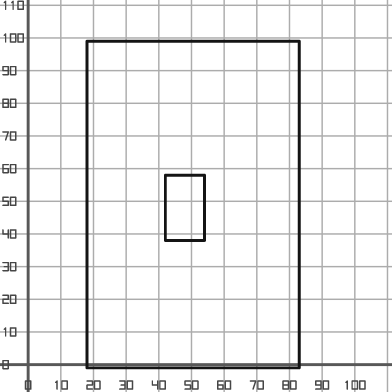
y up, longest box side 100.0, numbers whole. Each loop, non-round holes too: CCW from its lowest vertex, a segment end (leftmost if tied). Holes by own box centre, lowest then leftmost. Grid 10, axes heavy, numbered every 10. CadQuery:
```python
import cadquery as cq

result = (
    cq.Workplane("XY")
    .moveTo(18.0, -1.0)
    .lineTo(83.0, -1.0)
    .lineTo(83.0, 99.0)
    .lineTo(18.0, 99.0)
    .close()
    .moveTo(42.0, 38.0)
    .lineTo(54.0, 38.0)
    .lineTo(54.0, 58.0)
    .lineTo(42.0, 58.0)
    .close()
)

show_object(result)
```